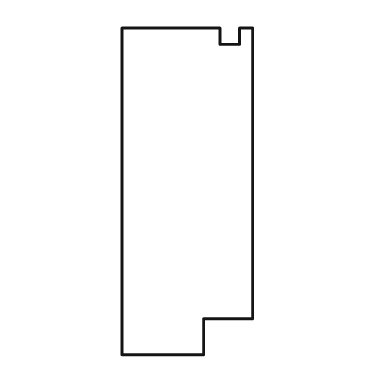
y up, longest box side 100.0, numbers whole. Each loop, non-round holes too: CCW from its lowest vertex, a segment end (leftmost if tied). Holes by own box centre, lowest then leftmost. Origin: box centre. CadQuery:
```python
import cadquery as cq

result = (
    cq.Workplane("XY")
    .moveTo(-20.0, -50.0)
    .lineTo(5.0, -50.0)
    .lineTo(5.0, -39.0)
    .lineTo(20.0, -39.0)
    .lineTo(20.0, 50.0)
    .lineTo(16.0, 50.0)
    .lineTo(16.0, 45.0)
    .lineTo(10.0, 45.0)
    .lineTo(10.0, 50.0)
    .lineTo(-20.0, 50.0)
    .close()
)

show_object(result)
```